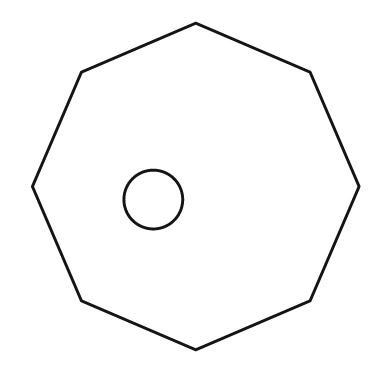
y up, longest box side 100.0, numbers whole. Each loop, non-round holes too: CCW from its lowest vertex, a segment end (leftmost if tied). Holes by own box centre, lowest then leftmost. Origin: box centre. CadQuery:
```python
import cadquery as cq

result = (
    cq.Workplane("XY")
    .moveTo(0.0, -50.0)
    .lineTo(35.0, -35.0)
    .lineTo(50.0, 0.0)
    .lineTo(35.0, 35.0)
    .lineTo(0.0, 50.0)
    .lineTo(-35.0, 35.0)
    .lineTo(-50.0, 0.0)
    .lineTo(-35.0, -35.0)
    .close()
    .moveTo(-13.0, -4.0)
    .circle(9.0)
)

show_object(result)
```